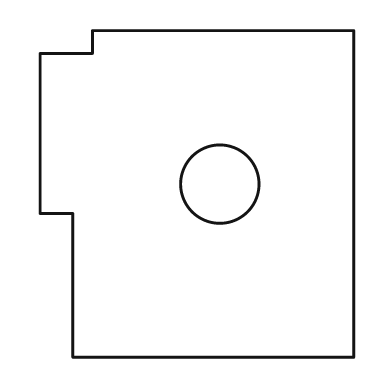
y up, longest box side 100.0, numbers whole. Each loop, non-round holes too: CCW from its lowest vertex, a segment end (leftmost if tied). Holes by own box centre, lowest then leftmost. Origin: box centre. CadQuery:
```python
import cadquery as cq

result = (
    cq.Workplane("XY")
    .moveTo(-38.0, -50.0)
    .lineTo(48.0, -50.0)
    .lineTo(48.0, 50.0)
    .lineTo(-32.0, 50.0)
    .lineTo(-32.0, 43.0)
    .lineTo(-48.0, 43.0)
    .lineTo(-48.0, -6.0)
    .lineTo(-38.0, -6.0)
    .close()
    .moveTo(7.0, 3.0)
    .circle(12.0)
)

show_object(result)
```